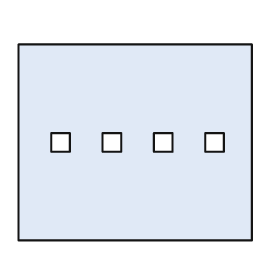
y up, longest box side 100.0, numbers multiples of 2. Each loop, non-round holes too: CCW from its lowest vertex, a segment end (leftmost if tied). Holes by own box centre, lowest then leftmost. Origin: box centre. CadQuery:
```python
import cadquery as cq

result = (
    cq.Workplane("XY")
    .moveTo(-50.0, -42.0)
    .lineTo(50.0, -42.0)
    .lineTo(50.0, 42.0)
    .lineTo(-50.0, 42.0)
    .close()
    .moveTo(-36.0, -4.0)
    .lineTo(-28.0, -4.0)
    .lineTo(-28.0, 4.0)
    .lineTo(-36.0, 4.0)
    .close()
    .moveTo(-14.0, -4.0)
    .lineTo(-6.0, -4.0)
    .lineTo(-6.0, 4.0)
    .lineTo(-14.0, 4.0)
    .close()
    .moveTo(8.0, -4.0)
    .lineTo(16.0, -4.0)
    .lineTo(16.0, 4.0)
    .lineTo(8.0, 4.0)
    .close()
    .moveTo(30.0, -4.0)
    .lineTo(38.0, -4.0)
    .lineTo(38.0, 4.0)
    .lineTo(30.0, 4.0)
    .close()
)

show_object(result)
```